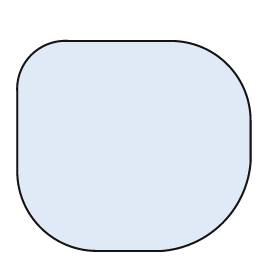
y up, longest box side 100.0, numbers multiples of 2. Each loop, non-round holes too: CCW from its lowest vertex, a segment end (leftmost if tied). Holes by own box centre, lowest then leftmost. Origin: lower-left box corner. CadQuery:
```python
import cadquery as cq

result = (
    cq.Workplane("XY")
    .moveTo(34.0, 0.0)
    .lineTo(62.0, 0.0)
    .threePointArc((88.0, 12.0), (100.0, 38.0))
    .lineTo(100.0, 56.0)
    .threePointArc((90.0, 80.0), (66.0, 90.0))
    .lineTo(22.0, 90.0)
    .threePointArc((6.0, 84.0), (0.0, 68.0))
    .lineTo(0.0, 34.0)
    .threePointArc((10.0, 10.0), (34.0, 0.0))
    .close()
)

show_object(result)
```